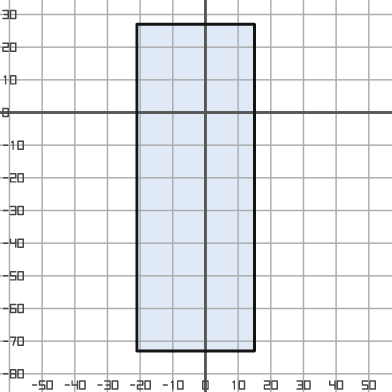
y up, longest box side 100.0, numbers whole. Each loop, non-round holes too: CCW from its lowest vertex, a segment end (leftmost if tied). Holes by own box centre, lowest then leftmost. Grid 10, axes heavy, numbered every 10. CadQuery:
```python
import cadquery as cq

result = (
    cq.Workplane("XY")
    .moveTo(-21.0, -73.0)
    .lineTo(15.0, -73.0)
    .lineTo(15.0, 27.0)
    .lineTo(-21.0, 27.0)
    .close()
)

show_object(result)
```